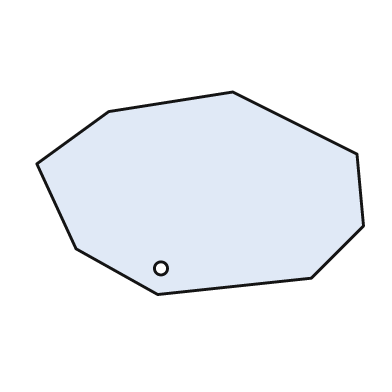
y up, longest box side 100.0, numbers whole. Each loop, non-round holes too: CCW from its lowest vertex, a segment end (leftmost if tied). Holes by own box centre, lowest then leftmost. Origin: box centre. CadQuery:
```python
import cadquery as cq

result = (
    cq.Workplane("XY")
    .moveTo(-13.0, -31.0)
    .lineTo(34.0, -26.0)
    .lineTo(50.0, -10.0)
    .lineTo(48.0, 12.0)
    .lineTo(10.0, 31.0)
    .lineTo(-28.0, 25.0)
    .lineTo(-50.0, 9.0)
    .lineTo(-38.0, -17.0)
    .close()
    .moveTo(-12.0, -23.0)
    .circle(2.0)
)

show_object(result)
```